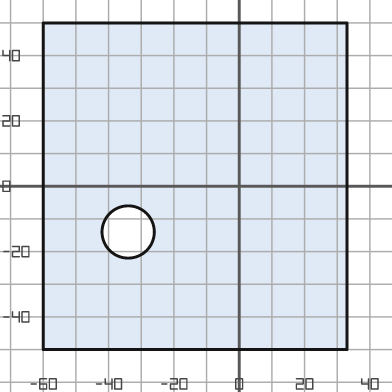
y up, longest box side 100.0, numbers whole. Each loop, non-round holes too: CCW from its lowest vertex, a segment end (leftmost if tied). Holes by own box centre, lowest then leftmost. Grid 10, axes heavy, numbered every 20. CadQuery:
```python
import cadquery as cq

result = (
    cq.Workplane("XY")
    .moveTo(-60.0, -50.0)
    .lineTo(33.0, -50.0)
    .lineTo(33.0, 50.0)
    .lineTo(-60.0, 50.0)
    .close()
    .moveTo(-34.0, -14.0)
    .circle(8.0)
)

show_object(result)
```